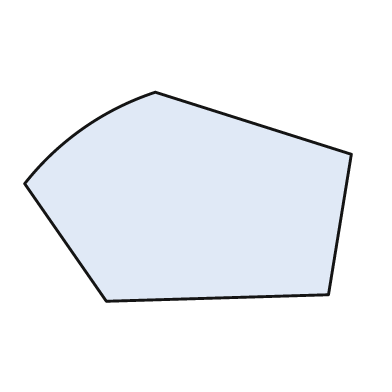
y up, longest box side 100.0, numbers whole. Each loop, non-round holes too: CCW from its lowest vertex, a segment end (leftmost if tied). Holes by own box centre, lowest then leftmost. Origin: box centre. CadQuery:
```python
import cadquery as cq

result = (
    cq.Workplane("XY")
    .moveTo(-25.0, -32.0)
    .lineTo(43.0, -30.0)
    .lineTo(50.0, 13.0)
    .lineTo(-10.0, 32.0)
    .threePointArc((-32.0, 21.0), (-50.0, 4.0))
    .close()
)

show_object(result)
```